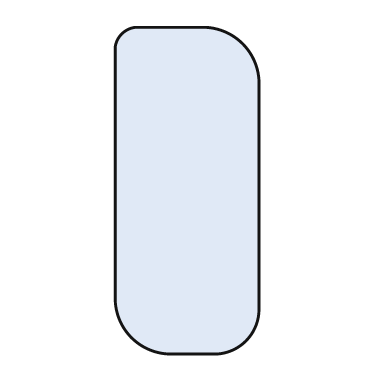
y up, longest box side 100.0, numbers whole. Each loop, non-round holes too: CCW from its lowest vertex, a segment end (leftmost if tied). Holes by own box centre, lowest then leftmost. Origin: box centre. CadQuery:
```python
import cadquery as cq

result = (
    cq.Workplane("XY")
    .moveTo(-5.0, -50.0)
    .lineTo(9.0, -50.0)
    .threePointArc((18.0, -46.0), (22.0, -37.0))
    .lineTo(22.0, 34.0)
    .threePointArc((17.0, 45.0), (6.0, 50.0))
    .lineTo(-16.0, 50.0)
    .threePointArc((-20.0, 48.0), (-22.0, 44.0))
    .lineTo(-22.0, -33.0)
    .threePointArc((-17.0, -45.0), (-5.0, -50.0))
    .close()
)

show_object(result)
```